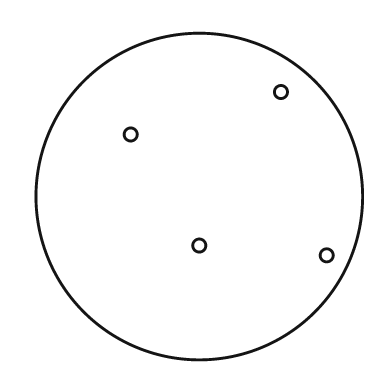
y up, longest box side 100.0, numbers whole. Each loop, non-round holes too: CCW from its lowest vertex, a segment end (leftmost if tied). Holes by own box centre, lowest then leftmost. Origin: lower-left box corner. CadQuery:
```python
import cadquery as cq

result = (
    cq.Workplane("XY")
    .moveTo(50.0, 50.0)
    .circle(50.0)
    .moveTo(89.0, 32.0)
    .circle(2.0)
    .moveTo(50.0, 35.0)
    .circle(2.0)
    .moveTo(29.0, 69.0)
    .circle(2.0)
    .moveTo(75.0, 82.0)
    .circle(2.0)
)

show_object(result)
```